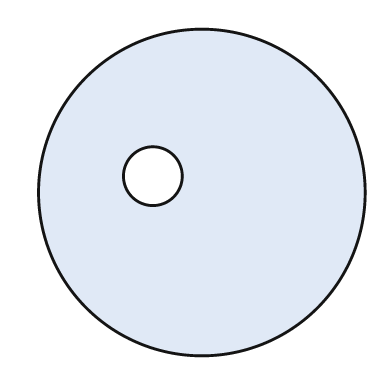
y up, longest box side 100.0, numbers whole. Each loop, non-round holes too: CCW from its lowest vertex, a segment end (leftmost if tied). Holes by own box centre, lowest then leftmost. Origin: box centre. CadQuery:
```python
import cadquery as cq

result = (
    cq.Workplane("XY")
    .moveTo(0.0, 0.0)
    .circle(50.0)
    .moveTo(-15.0, 5.0)
    .circle(9.0)
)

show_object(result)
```